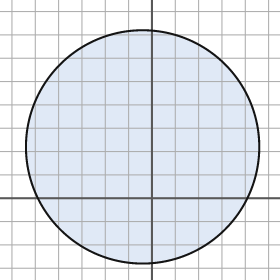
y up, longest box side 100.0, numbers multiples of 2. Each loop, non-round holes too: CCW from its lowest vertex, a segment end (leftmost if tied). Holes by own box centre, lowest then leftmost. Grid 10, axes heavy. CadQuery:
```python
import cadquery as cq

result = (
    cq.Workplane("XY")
    .moveTo(-4.0, 22.0)
    .circle(50.0)
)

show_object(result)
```